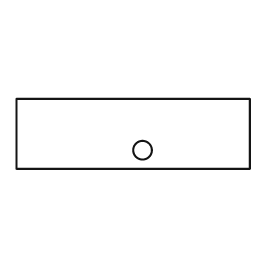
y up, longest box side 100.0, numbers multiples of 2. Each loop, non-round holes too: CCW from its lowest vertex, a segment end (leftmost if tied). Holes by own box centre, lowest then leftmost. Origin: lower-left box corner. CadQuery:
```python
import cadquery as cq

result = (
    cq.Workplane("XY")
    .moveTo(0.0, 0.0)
    .lineTo(100.0, 0.0)
    .lineTo(100.0, 30.0)
    .lineTo(0.0, 30.0)
    .close()
    .moveTo(54.0, 8.0)
    .circle(4.0)
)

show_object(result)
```